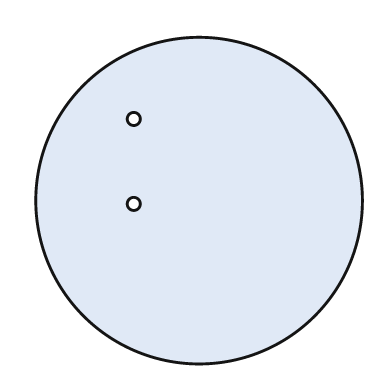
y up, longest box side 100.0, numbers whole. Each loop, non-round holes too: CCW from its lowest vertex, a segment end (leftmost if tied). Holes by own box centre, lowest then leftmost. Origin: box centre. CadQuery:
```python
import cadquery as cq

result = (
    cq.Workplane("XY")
    .moveTo(0.0, 0.0)
    .circle(50.0)
    .moveTo(-20.0, -1.0)
    .circle(2.0)
    .moveTo(-20.0, 25.0)
    .circle(2.0)
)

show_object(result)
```